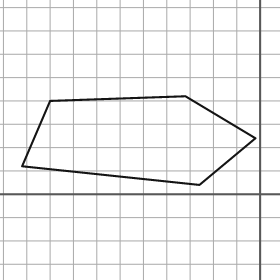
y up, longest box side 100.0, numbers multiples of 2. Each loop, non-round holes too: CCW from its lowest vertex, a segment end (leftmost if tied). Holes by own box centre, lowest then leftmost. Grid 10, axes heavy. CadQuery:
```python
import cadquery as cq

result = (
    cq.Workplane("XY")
    .moveTo(-26.0, 4.0)
    .lineTo(-2.0, 24.0)
    .lineTo(-32.0, 42.0)
    .lineTo(-90.0, 40.0)
    .lineTo(-102.0, 12.0)
    .close()
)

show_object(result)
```